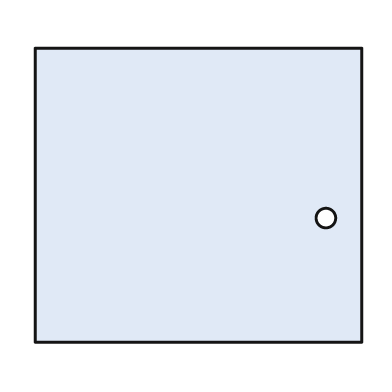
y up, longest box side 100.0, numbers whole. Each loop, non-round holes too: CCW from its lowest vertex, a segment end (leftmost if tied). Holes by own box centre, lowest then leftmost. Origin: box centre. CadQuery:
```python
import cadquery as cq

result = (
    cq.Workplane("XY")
    .moveTo(-50.0, -45.0)
    .lineTo(50.0, -45.0)
    .lineTo(50.0, 45.0)
    .lineTo(-50.0, 45.0)
    .close()
    .moveTo(39.0, -7.0)
    .circle(3.0)
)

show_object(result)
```